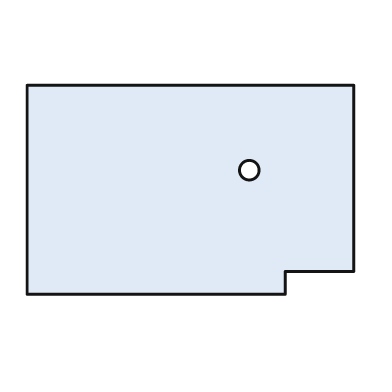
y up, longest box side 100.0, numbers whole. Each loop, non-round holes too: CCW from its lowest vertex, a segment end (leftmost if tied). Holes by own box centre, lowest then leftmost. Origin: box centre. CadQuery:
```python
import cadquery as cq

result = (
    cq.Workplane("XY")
    .moveTo(-50.0, -32.0)
    .lineTo(29.0, -32.0)
    .lineTo(29.0, -25.0)
    .lineTo(50.0, -25.0)
    .lineTo(50.0, 32.0)
    .lineTo(-50.0, 32.0)
    .close()
    .moveTo(18.0, 6.0)
    .circle(3.0)
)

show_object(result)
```